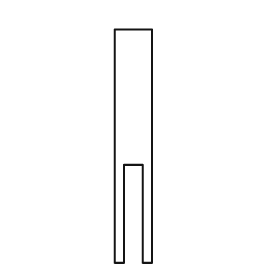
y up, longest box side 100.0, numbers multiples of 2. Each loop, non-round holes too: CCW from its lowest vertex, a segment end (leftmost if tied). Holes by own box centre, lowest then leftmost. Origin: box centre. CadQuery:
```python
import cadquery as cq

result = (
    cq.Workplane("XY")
    .moveTo(-8.0, -50.0)
    .lineTo(-4.0, -50.0)
    .lineTo(-4.0, -8.0)
    .lineTo(4.0, -8.0)
    .lineTo(4.0, -50.0)
    .lineTo(8.0, -50.0)
    .lineTo(8.0, 50.0)
    .lineTo(-8.0, 50.0)
    .close()
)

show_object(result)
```